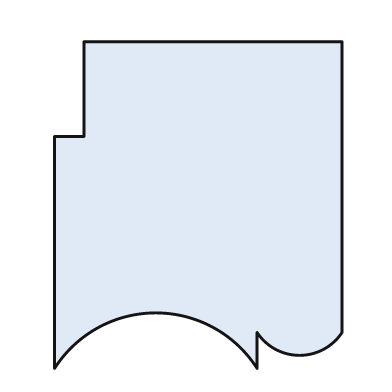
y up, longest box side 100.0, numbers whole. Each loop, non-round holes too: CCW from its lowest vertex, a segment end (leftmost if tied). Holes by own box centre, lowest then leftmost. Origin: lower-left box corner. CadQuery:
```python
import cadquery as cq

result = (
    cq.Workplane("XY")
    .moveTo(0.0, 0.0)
    .threePointArc((31.0, 17.0), (62.0, 0.0))
    .lineTo(62.0, 11.0)
    .threePointArc((75.0, 4.0), (88.0, 11.0))
    .lineTo(88.0, 100.0)
    .lineTo(9.0, 100.0)
    .lineTo(9.0, 71.0)
    .lineTo(0.0, 71.0)
    .close()
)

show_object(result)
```